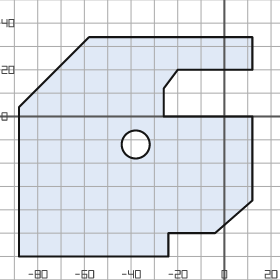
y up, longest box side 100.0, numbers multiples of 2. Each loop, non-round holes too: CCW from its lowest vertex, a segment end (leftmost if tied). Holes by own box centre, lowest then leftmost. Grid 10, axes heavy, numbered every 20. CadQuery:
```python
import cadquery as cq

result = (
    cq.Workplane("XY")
    .moveTo(-88.0, -60.0)
    .lineTo(-24.0, -60.0)
    .lineTo(-24.0, -50.0)
    .lineTo(-4.0, -50.0)
    .lineTo(12.0, -36.0)
    .lineTo(12.0, 0.0)
    .lineTo(-26.0, 0.0)
    .lineTo(-26.0, 12.0)
    .lineTo(-20.0, 20.0)
    .lineTo(12.0, 20.0)
    .lineTo(12.0, 34.0)
    .lineTo(-58.0, 34.0)
    .lineTo(-88.0, 4.0)
    .close()
    .moveTo(-38.0, -12.0)
    .circle(6.0)
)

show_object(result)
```